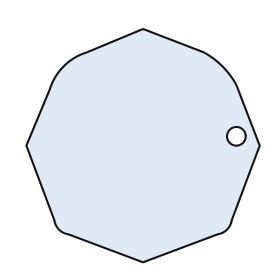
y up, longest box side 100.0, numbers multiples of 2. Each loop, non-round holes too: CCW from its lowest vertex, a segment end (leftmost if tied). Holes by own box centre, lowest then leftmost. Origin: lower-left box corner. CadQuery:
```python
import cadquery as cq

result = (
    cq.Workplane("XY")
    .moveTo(50.0, 0.0)
    .lineTo(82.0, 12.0)
    .threePointArc((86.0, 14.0), (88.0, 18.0))
    .lineTo(100.0, 50.0)
    .lineTo(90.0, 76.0)
    .threePointArc((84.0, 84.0), (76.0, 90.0))
    .lineTo(50.0, 100.0)
    .lineTo(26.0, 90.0)
    .threePointArc((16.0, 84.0), (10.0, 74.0))
    .lineTo(0.0, 50.0)
    .lineTo(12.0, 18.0)
    .threePointArc((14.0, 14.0), (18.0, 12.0))
    .close()
    .moveTo(90.0, 54.0)
    .circle(4.0)
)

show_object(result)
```